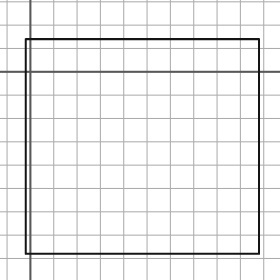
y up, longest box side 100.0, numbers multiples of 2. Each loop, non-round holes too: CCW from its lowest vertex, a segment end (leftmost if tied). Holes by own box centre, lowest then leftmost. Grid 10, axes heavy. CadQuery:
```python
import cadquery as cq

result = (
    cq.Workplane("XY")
    .moveTo(-2.0, -78.0)
    .lineTo(98.0, -78.0)
    .lineTo(98.0, 14.0)
    .lineTo(-2.0, 14.0)
    .close()
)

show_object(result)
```